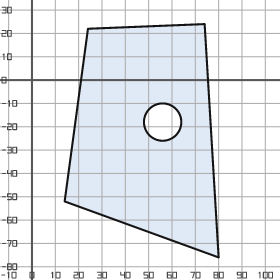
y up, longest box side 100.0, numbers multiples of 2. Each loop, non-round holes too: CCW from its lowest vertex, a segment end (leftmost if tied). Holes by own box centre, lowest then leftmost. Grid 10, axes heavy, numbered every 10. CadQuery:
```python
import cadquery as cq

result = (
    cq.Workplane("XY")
    .moveTo(80.0, -76.0)
    .lineTo(74.0, 24.0)
    .lineTo(24.0, 22.0)
    .lineTo(14.0, -52.0)
    .close()
    .moveTo(56.0, -18.0)
    .circle(8.0)
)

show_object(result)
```